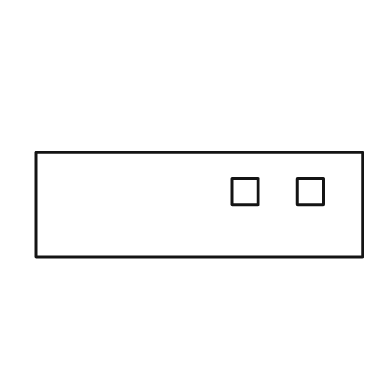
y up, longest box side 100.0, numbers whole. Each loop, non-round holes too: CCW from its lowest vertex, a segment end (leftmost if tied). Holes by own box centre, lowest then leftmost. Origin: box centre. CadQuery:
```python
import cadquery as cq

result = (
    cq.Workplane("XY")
    .moveTo(-50.0, -16.0)
    .lineTo(50.0, -16.0)
    .lineTo(50.0, 16.0)
    .lineTo(-50.0, 16.0)
    .close()
    .moveTo(10.0, 0.0)
    .lineTo(18.0, 0.0)
    .lineTo(18.0, 8.0)
    .lineTo(10.0, 8.0)
    .close()
    .moveTo(30.0, 0.0)
    .lineTo(38.0, 0.0)
    .lineTo(38.0, 8.0)
    .lineTo(30.0, 8.0)
    .close()
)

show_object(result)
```